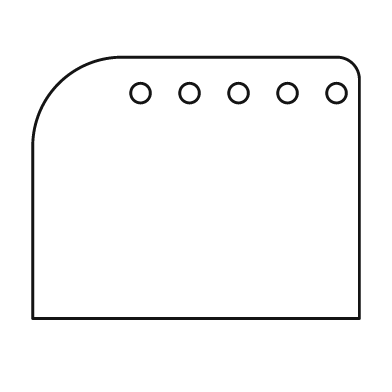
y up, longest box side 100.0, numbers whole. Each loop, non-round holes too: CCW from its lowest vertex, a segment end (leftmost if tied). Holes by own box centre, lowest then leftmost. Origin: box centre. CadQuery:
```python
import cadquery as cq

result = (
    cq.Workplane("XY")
    .moveTo(-50.0, -40.0)
    .lineTo(50.0, -40.0)
    .lineTo(50.0, 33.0)
    .threePointArc((48.0, 38.0), (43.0, 40.0))
    .lineTo(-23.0, 40.0)
    .threePointArc((-42.0, 32.0), (-50.0, 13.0))
    .close()
    .moveTo(-17.0, 29.0)
    .circle(3.0)
    .moveTo(-2.0, 29.0)
    .circle(3.0)
    .moveTo(13.0, 29.0)
    .circle(3.0)
    .moveTo(28.0, 29.0)
    .circle(3.0)
    .moveTo(43.0, 29.0)
    .circle(3.0)
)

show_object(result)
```